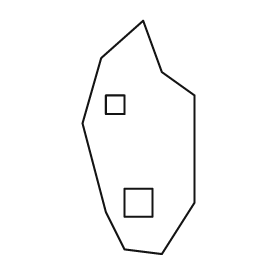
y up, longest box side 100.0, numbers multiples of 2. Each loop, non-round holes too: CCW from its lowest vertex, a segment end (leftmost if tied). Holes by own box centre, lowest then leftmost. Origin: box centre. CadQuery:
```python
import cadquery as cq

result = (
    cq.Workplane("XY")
    .moveTo(10.0, -50.0)
    .lineTo(24.0, -28.0)
    .lineTo(24.0, 18.0)
    .lineTo(10.0, 28.0)
    .lineTo(2.0, 50.0)
    .lineTo(-16.0, 34.0)
    .lineTo(-24.0, 6.0)
    .lineTo(-14.0, -32.0)
    .lineTo(-6.0, -48.0)
    .close()
    .moveTo(-6.0, -34.0)
    .lineTo(6.0, -34.0)
    .lineTo(6.0, -22.0)
    .lineTo(-6.0, -22.0)
    .close()
    .moveTo(-14.0, 10.0)
    .lineTo(-6.0, 10.0)
    .lineTo(-6.0, 18.0)
    .lineTo(-14.0, 18.0)
    .close()
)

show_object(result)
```